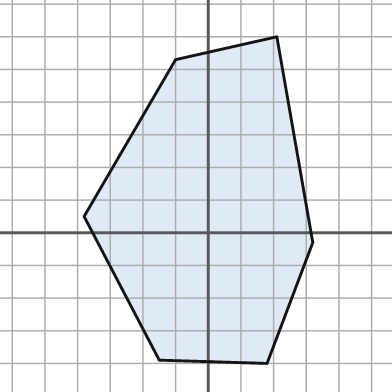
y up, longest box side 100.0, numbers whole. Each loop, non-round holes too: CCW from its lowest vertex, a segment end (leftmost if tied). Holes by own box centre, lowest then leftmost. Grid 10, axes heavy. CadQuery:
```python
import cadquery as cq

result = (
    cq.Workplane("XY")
    .moveTo(18.0, -40.0)
    .lineTo(32.0, -3.0)
    .lineTo(21.0, 60.0)
    .lineTo(-10.0, 53.0)
    .lineTo(-38.0, 5.0)
    .lineTo(-15.0, -39.0)
    .close()
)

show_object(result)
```